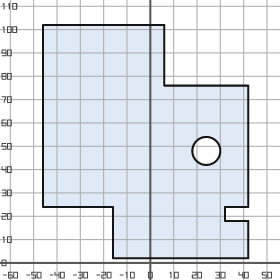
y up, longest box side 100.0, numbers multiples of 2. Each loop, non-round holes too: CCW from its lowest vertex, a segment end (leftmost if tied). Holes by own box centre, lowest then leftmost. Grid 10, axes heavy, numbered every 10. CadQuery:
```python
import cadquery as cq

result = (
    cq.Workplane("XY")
    .moveTo(-16.0, 2.0)
    .lineTo(42.0, 2.0)
    .lineTo(42.0, 18.0)
    .lineTo(32.0, 18.0)
    .lineTo(32.0, 24.0)
    .lineTo(42.0, 24.0)
    .lineTo(42.0, 76.0)
    .lineTo(6.0, 76.0)
    .lineTo(6.0, 102.0)
    .lineTo(-46.0, 102.0)
    .lineTo(-46.0, 24.0)
    .lineTo(-16.0, 24.0)
    .close()
    .moveTo(24.0, 48.0)
    .circle(6.0)
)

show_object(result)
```